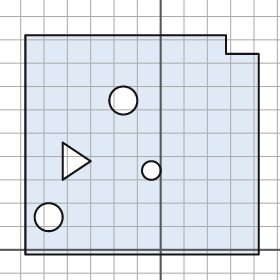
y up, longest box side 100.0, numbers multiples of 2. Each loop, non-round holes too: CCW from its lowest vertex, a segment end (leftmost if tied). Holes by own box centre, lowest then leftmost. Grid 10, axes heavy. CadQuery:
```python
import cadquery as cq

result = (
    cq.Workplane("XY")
    .moveTo(-58.0, -2.0)
    .lineTo(42.0, -2.0)
    .lineTo(42.0, 84.0)
    .lineTo(28.0, 84.0)
    .lineTo(28.0, 92.0)
    .lineTo(-58.0, 92.0)
    .close()
    .moveTo(-48.0, 14.0)
    .circle(6.0)
    .moveTo(-4.0, 34.0)
    .circle(4.0)
    .moveTo(-42.0, 30.0)
    .lineTo(-30.0, 38.0)
    .lineTo(-42.0, 46.0)
    .close()
    .moveTo(-16.0, 64.0)
    .circle(6.0)
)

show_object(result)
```